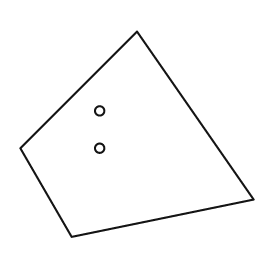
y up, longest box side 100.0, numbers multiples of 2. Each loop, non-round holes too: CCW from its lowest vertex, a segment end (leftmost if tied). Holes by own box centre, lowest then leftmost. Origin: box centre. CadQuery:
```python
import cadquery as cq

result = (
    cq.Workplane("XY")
    .moveTo(-28.0, -44.0)
    .lineTo(50.0, -28.0)
    .lineTo(0.0, 44.0)
    .lineTo(-50.0, -6.0)
    .close()
    .moveTo(-16.0, -6.0)
    .circle(2.0)
    .moveTo(-16.0, 10.0)
    .circle(2.0)
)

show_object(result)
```